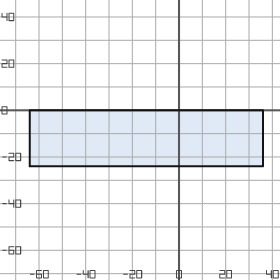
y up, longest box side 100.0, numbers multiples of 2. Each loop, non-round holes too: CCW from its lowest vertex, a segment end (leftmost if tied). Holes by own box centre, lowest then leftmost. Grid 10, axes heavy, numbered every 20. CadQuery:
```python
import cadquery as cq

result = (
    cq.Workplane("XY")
    .moveTo(-64.0, -24.0)
    .lineTo(36.0, -24.0)
    .lineTo(36.0, 0.0)
    .lineTo(-64.0, 0.0)
    .close()
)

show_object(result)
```